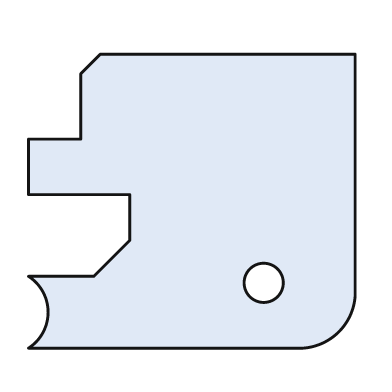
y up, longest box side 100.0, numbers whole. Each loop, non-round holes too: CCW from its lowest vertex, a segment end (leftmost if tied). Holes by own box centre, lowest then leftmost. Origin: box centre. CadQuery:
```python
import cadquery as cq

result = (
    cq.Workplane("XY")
    .moveTo(-50.0, -45.0)
    .lineTo(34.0, -45.0)
    .threePointArc((45.0, -40.0), (50.0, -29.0))
    .lineTo(50.0, 45.0)
    .lineTo(-28.0, 45.0)
    .lineTo(-34.0, 39.0)
    .lineTo(-34.0, 19.0)
    .lineTo(-50.0, 19.0)
    .lineTo(-50.0, 2.0)
    .lineTo(-19.0, 2.0)
    .lineTo(-19.0, -12.0)
    .lineTo(-30.0, -23.0)
    .lineTo(-50.0, -23.0)
    .threePointArc((-44.0, -34.0), (-50.0, -45.0))
    .close()
    .moveTo(22.0, -25.0)
    .circle(6.0)
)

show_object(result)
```